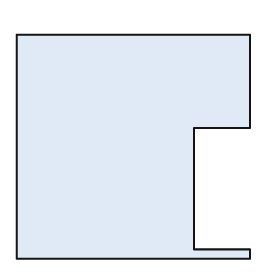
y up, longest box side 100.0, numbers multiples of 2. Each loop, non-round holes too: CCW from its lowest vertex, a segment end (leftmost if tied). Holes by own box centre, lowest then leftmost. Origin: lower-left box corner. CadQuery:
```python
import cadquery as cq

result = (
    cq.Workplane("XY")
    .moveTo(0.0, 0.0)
    .lineTo(100.0, 0.0)
    .lineTo(100.0, 4.0)
    .lineTo(76.0, 4.0)
    .lineTo(76.0, 56.0)
    .lineTo(100.0, 56.0)
    .lineTo(100.0, 96.0)
    .lineTo(0.0, 96.0)
    .close()
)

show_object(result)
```